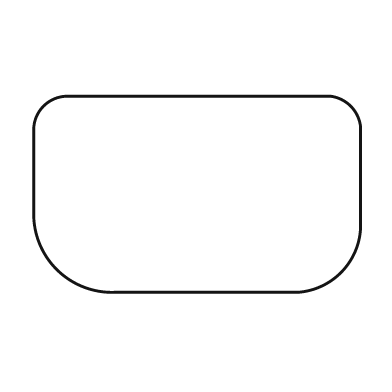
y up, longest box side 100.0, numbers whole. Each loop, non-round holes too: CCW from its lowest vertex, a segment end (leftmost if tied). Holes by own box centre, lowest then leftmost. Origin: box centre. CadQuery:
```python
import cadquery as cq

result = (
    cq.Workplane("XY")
    .moveTo(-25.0, -30.0)
    .lineTo(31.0, -30.0)
    .threePointArc((44.0, -24.0), (50.0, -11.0))
    .lineTo(50.0, 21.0)
    .threePointArc((47.0, 27.0), (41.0, 30.0))
    .lineTo(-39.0, 30.0)
    .threePointArc((-47.0, 27.0), (-50.0, 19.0))
    .lineTo(-50.0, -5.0)
    .threePointArc((-43.0, -23.0), (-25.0, -30.0))
    .close()
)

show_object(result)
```